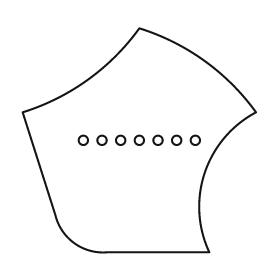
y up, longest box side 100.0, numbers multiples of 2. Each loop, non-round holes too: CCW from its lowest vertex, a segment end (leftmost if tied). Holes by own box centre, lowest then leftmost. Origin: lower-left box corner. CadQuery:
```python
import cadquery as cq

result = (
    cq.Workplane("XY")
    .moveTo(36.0, 0.0)
    .lineTo(80.0, 0.0)
    .threePointArc((78.0, 34.0), (100.0, 60.0))
    .threePointArc((78.0, 82.0), (50.0, 96.0))
    .threePointArc((28.0, 74.0), (0.0, 60.0))
    .lineTo(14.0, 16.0)
    .threePointArc((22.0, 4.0), (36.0, 0.0))
    .close()
    .moveTo(26.0, 48.0)
    .circle(2.0)
    .moveTo(34.0, 48.0)
    .circle(2.0)
    .moveTo(42.0, 48.0)
    .circle(2.0)
    .moveTo(50.0, 48.0)
    .circle(2.0)
    .moveTo(58.0, 48.0)
    .circle(2.0)
    .moveTo(66.0, 48.0)
    .circle(2.0)
    .moveTo(74.0, 48.0)
    .circle(2.0)
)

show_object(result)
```